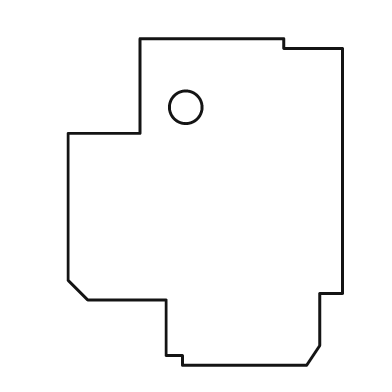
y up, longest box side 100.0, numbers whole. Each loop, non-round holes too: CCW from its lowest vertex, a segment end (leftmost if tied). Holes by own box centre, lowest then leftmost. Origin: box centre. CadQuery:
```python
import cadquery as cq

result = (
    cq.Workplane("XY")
    .moveTo(-7.0, -50.0)
    .lineTo(31.0, -50.0)
    .lineTo(35.0, -44.0)
    .lineTo(35.0, -28.0)
    .lineTo(42.0, -28.0)
    .lineTo(42.0, 47.0)
    .lineTo(24.0, 47.0)
    .lineTo(24.0, 50.0)
    .lineTo(-20.0, 50.0)
    .lineTo(-20.0, 21.0)
    .lineTo(-42.0, 21.0)
    .lineTo(-42.0, -24.0)
    .lineTo(-36.0, -30.0)
    .lineTo(-12.0, -30.0)
    .lineTo(-12.0, -47.0)
    .lineTo(-7.0, -47.0)
    .close()
    .moveTo(-6.0, 29.0)
    .circle(5.0)
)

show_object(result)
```